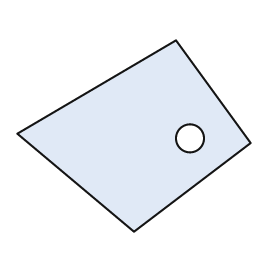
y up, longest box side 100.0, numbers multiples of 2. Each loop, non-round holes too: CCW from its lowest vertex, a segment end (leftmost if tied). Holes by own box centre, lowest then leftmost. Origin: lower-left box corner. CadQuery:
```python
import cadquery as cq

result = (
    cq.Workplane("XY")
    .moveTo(50.0, 0.0)
    .lineTo(100.0, 38.0)
    .lineTo(68.0, 82.0)
    .lineTo(0.0, 42.0)
    .close()
    .moveTo(74.0, 40.0)
    .circle(6.0)
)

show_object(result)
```